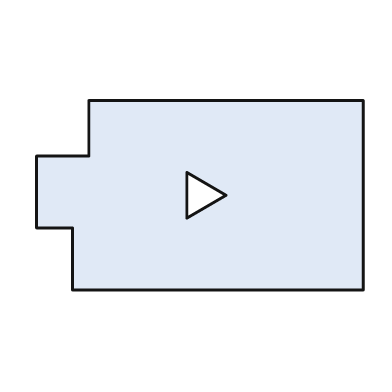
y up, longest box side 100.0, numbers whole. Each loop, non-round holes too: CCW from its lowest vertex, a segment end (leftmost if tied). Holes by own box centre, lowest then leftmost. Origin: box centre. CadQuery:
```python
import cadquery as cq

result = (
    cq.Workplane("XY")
    .moveTo(-39.0, -29.0)
    .lineTo(50.0, -29.0)
    .lineTo(50.0, 29.0)
    .lineTo(-34.0, 29.0)
    .lineTo(-34.0, 12.0)
    .lineTo(-50.0, 12.0)
    .lineTo(-50.0, -10.0)
    .lineTo(-39.0, -10.0)
    .close()
    .moveTo(-4.0, -7.0)
    .lineTo(8.0, 0.0)
    .lineTo(-4.0, 7.0)
    .close()
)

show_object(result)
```